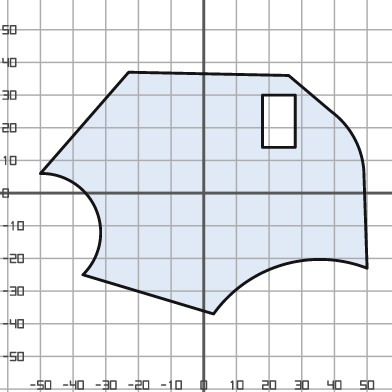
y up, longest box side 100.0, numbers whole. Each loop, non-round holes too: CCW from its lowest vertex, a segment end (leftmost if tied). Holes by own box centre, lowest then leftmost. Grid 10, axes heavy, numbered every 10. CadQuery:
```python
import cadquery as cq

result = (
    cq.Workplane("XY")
    .moveTo(3.0, -37.0)
    .threePointArc((24.0, -22.0), (50.0, -23.0))
    .lineTo(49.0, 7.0)
    .threePointArc((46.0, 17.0), (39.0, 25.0))
    .lineTo(26.0, 36.0)
    .lineTo(-23.0, 37.0)
    .lineTo(-50.0, 6.0)
    .threePointArc((-33.0, -5.0), (-37.0, -25.0))
    .close()
    .moveTo(18.0, 14.0)
    .lineTo(28.0, 14.0)
    .lineTo(28.0, 30.0)
    .lineTo(18.0, 30.0)
    .close()
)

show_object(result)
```